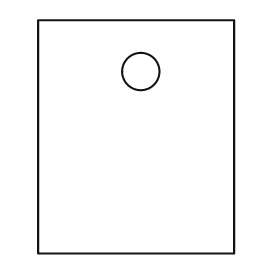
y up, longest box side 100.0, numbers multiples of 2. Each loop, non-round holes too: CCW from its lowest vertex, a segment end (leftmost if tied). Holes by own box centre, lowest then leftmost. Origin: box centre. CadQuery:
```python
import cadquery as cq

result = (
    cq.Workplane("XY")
    .moveTo(-42.0, -50.0)
    .lineTo(42.0, -50.0)
    .lineTo(42.0, 50.0)
    .lineTo(-42.0, 50.0)
    .close()
    .moveTo(2.0, 28.0)
    .circle(8.0)
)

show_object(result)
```